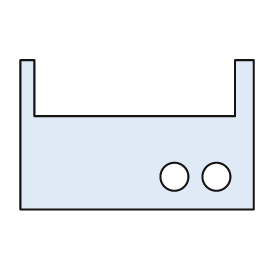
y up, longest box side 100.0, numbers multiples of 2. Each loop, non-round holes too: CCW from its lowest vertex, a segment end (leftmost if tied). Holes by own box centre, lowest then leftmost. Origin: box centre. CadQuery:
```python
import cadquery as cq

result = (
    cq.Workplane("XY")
    .moveTo(-50.0, -32.0)
    .lineTo(50.0, -32.0)
    .lineTo(50.0, 32.0)
    .lineTo(42.0, 32.0)
    .lineTo(42.0, 8.0)
    .lineTo(-44.0, 8.0)
    .lineTo(-44.0, 32.0)
    .lineTo(-50.0, 32.0)
    .close()
    .moveTo(16.0, -18.0)
    .circle(6.0)
    .moveTo(34.0, -18.0)
    .circle(6.0)
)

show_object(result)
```